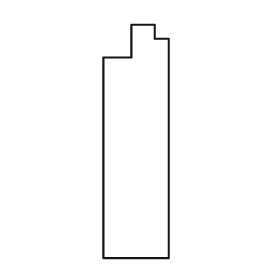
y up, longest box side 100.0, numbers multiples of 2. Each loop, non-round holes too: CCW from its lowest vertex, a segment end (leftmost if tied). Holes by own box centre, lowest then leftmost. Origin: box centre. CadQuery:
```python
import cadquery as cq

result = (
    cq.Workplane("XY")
    .moveTo(-14.0, -50.0)
    .lineTo(14.0, -50.0)
    .lineTo(14.0, 44.0)
    .lineTo(8.0, 44.0)
    .lineTo(8.0, 50.0)
    .lineTo(-2.0, 50.0)
    .lineTo(-2.0, 36.0)
    .lineTo(-14.0, 36.0)
    .close()
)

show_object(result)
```